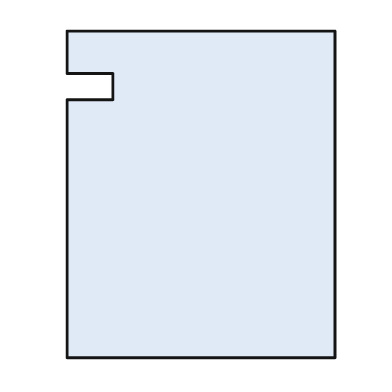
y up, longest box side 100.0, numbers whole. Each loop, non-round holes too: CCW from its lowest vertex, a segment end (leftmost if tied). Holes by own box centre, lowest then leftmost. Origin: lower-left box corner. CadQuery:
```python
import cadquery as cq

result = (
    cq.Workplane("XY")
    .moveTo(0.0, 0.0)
    .lineTo(82.0, 0.0)
    .lineTo(82.0, 100.0)
    .lineTo(0.0, 100.0)
    .lineTo(0.0, 87.0)
    .lineTo(14.0, 87.0)
    .lineTo(14.0, 79.0)
    .lineTo(0.0, 79.0)
    .close()
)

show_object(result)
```